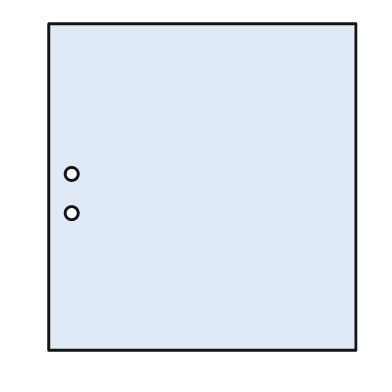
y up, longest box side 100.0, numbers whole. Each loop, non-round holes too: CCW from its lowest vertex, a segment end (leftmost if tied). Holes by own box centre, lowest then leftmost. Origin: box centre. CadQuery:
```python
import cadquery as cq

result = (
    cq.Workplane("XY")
    .moveTo(-47.0, -50.0)
    .lineTo(47.0, -50.0)
    .lineTo(47.0, 50.0)
    .lineTo(-47.0, 50.0)
    .close()
    .moveTo(-40.0, -8.0)
    .circle(2.0)
    .moveTo(-40.0, 4.0)
    .circle(2.0)
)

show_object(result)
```